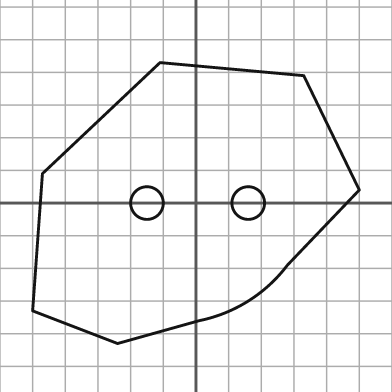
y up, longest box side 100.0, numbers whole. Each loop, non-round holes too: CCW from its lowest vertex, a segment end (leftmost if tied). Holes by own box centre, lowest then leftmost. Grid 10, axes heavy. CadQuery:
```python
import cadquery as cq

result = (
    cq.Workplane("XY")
    .moveTo(-24.0, -43.0)
    .lineTo(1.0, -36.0)
    .threePointArc((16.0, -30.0), (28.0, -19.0))
    .lineTo(50.0, 4.0)
    .lineTo(33.0, 39.0)
    .lineTo(-11.0, 43.0)
    .lineTo(-47.0, 9.0)
    .lineTo(-50.0, -33.0)
    .close()
    .moveTo(-15.0, 0.0)
    .circle(5.0)
    .moveTo(16.0, 0.0)
    .circle(5.0)
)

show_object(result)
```